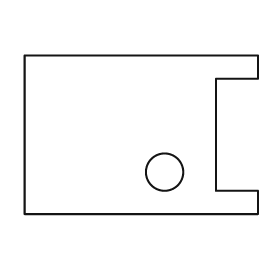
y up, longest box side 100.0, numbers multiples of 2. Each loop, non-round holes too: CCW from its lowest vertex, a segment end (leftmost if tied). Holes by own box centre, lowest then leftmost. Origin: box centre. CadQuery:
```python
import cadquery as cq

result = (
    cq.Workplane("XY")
    .moveTo(-50.0, -34.0)
    .lineTo(50.0, -34.0)
    .lineTo(50.0, -24.0)
    .lineTo(32.0, -24.0)
    .lineTo(32.0, 24.0)
    .lineTo(50.0, 24.0)
    .lineTo(50.0, 34.0)
    .lineTo(-50.0, 34.0)
    .close()
    .moveTo(10.0, -16.0)
    .circle(8.0)
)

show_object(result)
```